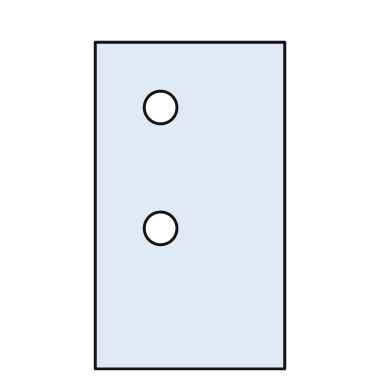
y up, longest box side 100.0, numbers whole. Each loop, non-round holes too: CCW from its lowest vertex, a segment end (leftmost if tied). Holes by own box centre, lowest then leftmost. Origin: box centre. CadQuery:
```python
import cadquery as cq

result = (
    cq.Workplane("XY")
    .moveTo(-29.0, -50.0)
    .lineTo(29.0, -50.0)
    .lineTo(29.0, 50.0)
    .lineTo(-29.0, 50.0)
    .close()
    .moveTo(-9.0, -7.0)
    .circle(5.0)
    .moveTo(-9.0, 30.0)
    .circle(5.0)
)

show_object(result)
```